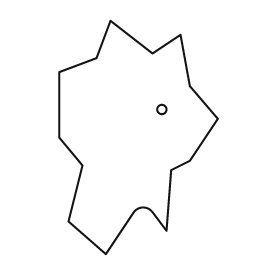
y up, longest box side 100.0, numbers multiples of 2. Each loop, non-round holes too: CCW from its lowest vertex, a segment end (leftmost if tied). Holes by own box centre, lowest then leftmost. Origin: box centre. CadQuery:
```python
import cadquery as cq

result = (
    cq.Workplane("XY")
    .moveTo(-14.0, -50.0)
    .lineTo(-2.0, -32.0)
    .threePointArc((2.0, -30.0), (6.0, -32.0))
    .lineTo(12.0, -40.0)
    .lineTo(14.0, -14.0)
    .lineTo(22.0, -10.0)
    .lineTo(34.0, 8.0)
    .lineTo(22.0, 22.0)
    .lineTo(18.0, 44.0)
    .lineTo(6.0, 36.0)
    .lineTo(-12.0, 50.0)
    .lineTo(-18.0, 34.0)
    .lineTo(-34.0, 28.0)
    .lineTo(-34.0, 0.0)
    .lineTo(-24.0, -12.0)
    .lineTo(-30.0, -36.0)
    .close()
    .moveTo(10.0, 12.0)
    .circle(2.0)
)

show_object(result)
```